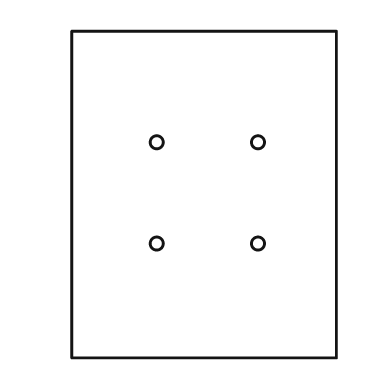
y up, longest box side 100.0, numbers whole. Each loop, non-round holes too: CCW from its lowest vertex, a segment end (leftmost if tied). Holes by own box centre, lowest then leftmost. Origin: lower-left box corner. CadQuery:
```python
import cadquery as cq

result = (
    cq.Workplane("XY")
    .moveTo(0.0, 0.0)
    .lineTo(81.0, 0.0)
    .lineTo(81.0, 100.0)
    .lineTo(0.0, 100.0)
    .close()
    .moveTo(26.0, 35.0)
    .circle(2.0)
    .moveTo(57.0, 35.0)
    .circle(2.0)
    .moveTo(26.0, 66.0)
    .circle(2.0)
    .moveTo(57.0, 66.0)
    .circle(2.0)
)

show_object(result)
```